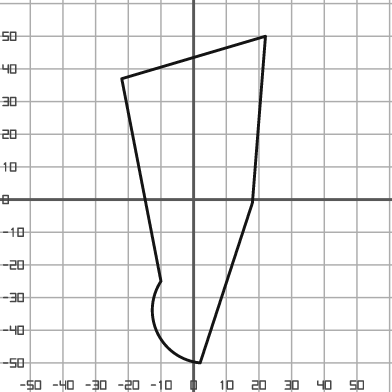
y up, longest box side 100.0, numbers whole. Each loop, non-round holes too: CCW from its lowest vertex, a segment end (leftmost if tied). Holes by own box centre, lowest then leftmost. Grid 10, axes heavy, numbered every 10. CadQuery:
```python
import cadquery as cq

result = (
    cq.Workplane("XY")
    .moveTo(2.0, -50.0)
    .lineTo(18.0, -1.0)
    .lineTo(22.0, 50.0)
    .lineTo(-22.0, 37.0)
    .lineTo(-10.0, -25.0)
    .threePointArc((-11.0, -41.0), (2.0, -50.0))
    .close()
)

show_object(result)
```